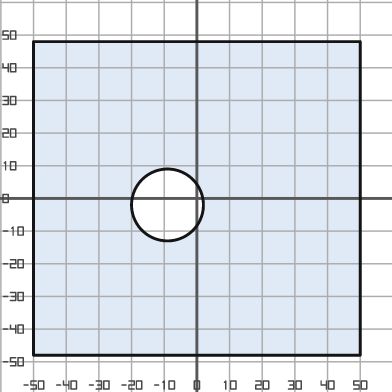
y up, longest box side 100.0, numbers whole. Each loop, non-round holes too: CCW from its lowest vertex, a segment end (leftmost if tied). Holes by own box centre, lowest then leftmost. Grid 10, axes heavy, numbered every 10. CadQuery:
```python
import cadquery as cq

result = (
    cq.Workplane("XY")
    .moveTo(-50.0, -48.0)
    .lineTo(50.0, -48.0)
    .lineTo(50.0, 48.0)
    .lineTo(-50.0, 48.0)
    .close()
    .moveTo(-9.0, -2.0)
    .circle(11.0)
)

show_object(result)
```